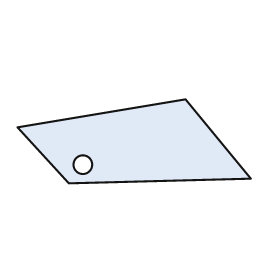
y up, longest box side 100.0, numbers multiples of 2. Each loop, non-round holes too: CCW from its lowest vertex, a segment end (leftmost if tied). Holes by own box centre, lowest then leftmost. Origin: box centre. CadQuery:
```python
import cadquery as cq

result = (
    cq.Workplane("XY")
    .moveTo(-28.0, -18.0)
    .lineTo(50.0, -16.0)
    .lineTo(22.0, 18.0)
    .lineTo(-50.0, 6.0)
    .close()
    .moveTo(-22.0, -10.0)
    .circle(4.0)
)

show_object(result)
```